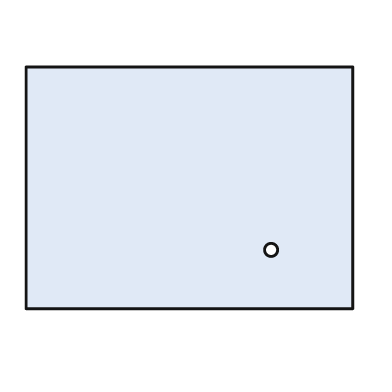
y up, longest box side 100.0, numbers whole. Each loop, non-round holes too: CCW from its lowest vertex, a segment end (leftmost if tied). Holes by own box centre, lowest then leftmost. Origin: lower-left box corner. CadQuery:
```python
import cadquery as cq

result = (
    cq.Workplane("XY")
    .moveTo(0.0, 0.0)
    .lineTo(100.0, 0.0)
    .lineTo(100.0, 74.0)
    .lineTo(0.0, 74.0)
    .close()
    .moveTo(75.0, 18.0)
    .circle(2.0)
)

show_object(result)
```